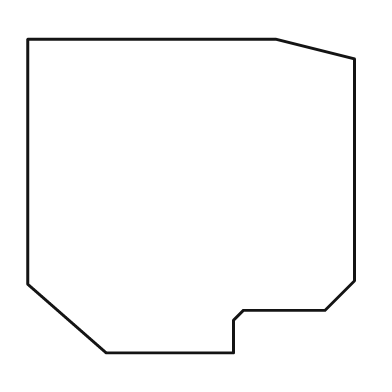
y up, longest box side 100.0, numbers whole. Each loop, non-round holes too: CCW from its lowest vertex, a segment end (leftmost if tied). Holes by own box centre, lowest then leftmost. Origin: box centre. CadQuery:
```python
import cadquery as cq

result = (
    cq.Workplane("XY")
    .moveTo(-26.0, -48.0)
    .lineTo(13.0, -48.0)
    .lineTo(13.0, -38.0)
    .lineTo(16.0, -35.0)
    .lineTo(41.0, -35.0)
    .lineTo(50.0, -26.0)
    .lineTo(50.0, 42.0)
    .lineTo(26.0, 48.0)
    .lineTo(-50.0, 48.0)
    .lineTo(-50.0, -27.0)
    .close()
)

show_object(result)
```